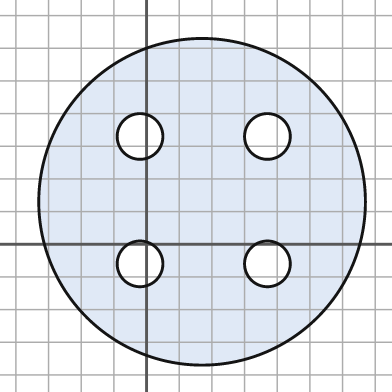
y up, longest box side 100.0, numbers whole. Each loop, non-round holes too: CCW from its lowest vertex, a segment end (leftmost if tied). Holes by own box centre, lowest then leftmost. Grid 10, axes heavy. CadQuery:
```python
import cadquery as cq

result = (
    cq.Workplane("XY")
    .moveTo(17.0, 13.0)
    .circle(50.0)
    .moveTo(-2.0, -6.0)
    .circle(7.0)
    .moveTo(37.0, -6.0)
    .circle(7.0)
    .moveTo(-2.0, 33.0)
    .circle(7.0)
    .moveTo(37.0, 33.0)
    .circle(7.0)
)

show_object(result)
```